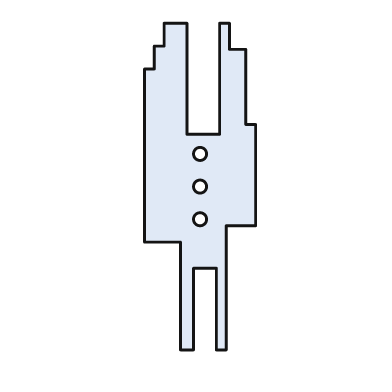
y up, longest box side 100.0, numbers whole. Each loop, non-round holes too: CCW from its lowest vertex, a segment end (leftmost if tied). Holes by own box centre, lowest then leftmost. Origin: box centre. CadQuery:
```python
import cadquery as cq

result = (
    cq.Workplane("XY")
    .moveTo(-6.0, -50.0)
    .lineTo(-2.0, -50.0)
    .lineTo(-2.0, -25.0)
    .lineTo(5.0, -25.0)
    .lineTo(5.0, -50.0)
    .lineTo(8.0, -50.0)
    .lineTo(8.0, -12.0)
    .lineTo(17.0, -12.0)
    .lineTo(17.0, 19.0)
    .lineTo(14.0, 19.0)
    .lineTo(14.0, 42.0)
    .lineTo(9.0, 42.0)
    .lineTo(9.0, 50.0)
    .lineTo(6.0, 50.0)
    .lineTo(6.0, 16.0)
    .lineTo(-4.0, 16.0)
    .lineTo(-4.0, 50.0)
    .lineTo(-11.0, 50.0)
    .lineTo(-11.0, 43.0)
    .lineTo(-14.0, 43.0)
    .lineTo(-14.0, 36.0)
    .lineTo(-17.0, 36.0)
    .lineTo(-17.0, -17.0)
    .lineTo(-6.0, -17.0)
    .close()
    .moveTo(0.0, -10.0)
    .circle(2.0)
    .moveTo(0.0, 0.0)
    .circle(2.0)
    .moveTo(0.0, 10.0)
    .circle(2.0)
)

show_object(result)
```